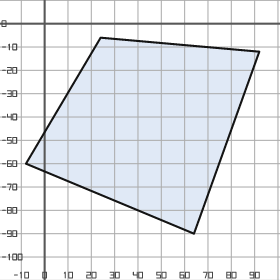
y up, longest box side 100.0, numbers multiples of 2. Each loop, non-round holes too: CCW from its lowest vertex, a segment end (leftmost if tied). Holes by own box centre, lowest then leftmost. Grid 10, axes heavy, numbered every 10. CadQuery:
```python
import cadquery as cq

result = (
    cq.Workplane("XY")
    .moveTo(64.0, -90.0)
    .lineTo(92.0, -12.0)
    .lineTo(24.0, -6.0)
    .lineTo(-8.0, -60.0)
    .close()
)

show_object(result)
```